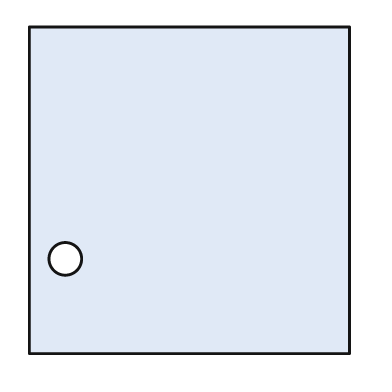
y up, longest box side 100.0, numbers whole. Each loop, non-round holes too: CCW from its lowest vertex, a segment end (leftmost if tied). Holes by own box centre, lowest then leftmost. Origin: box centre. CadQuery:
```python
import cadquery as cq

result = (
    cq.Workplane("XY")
    .moveTo(-49.0, -50.0)
    .lineTo(49.0, -50.0)
    .lineTo(49.0, 50.0)
    .lineTo(-49.0, 50.0)
    .close()
    .moveTo(-38.0, -21.0)
    .circle(5.0)
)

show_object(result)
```